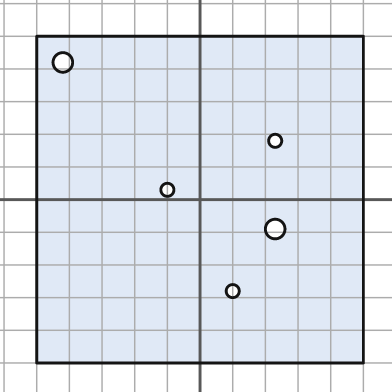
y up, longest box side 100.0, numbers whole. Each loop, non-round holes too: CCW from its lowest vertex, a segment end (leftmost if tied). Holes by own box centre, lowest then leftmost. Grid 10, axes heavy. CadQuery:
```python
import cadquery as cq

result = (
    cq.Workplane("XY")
    .moveTo(-50.0, -50.0)
    .lineTo(50.0, -50.0)
    .lineTo(50.0, 50.0)
    .lineTo(-50.0, 50.0)
    .close()
    .moveTo(10.0, -28.0)
    .circle(2.0)
    .moveTo(23.0, -9.0)
    .circle(3.0)
    .moveTo(-10.0, 3.0)
    .circle(2.0)
    .moveTo(23.0, 18.0)
    .circle(2.0)
    .moveTo(-42.0, 42.0)
    .circle(3.0)
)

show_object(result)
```